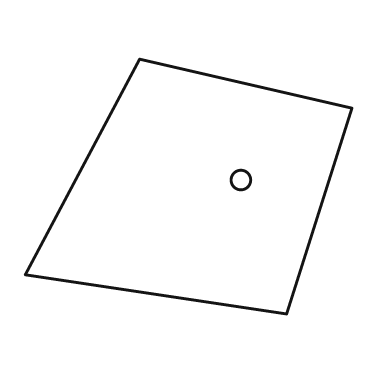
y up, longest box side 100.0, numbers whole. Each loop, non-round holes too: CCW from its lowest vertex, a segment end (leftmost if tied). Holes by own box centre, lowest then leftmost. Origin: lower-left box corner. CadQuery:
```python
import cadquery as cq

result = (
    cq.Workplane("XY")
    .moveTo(80.0, 0.0)
    .lineTo(100.0, 63.0)
    .lineTo(35.0, 78.0)
    .lineTo(0.0, 12.0)
    .close()
    .moveTo(66.0, 41.0)
    .circle(3.0)
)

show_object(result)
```